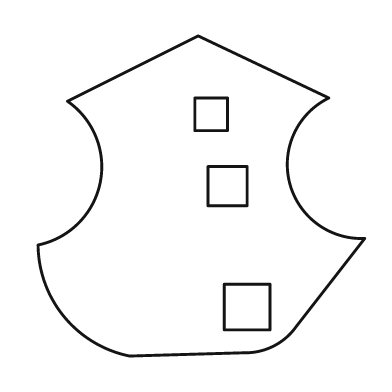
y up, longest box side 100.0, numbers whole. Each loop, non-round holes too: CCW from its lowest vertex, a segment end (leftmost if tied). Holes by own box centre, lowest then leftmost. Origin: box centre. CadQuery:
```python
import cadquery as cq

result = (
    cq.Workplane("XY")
    .moveTo(-22.0, -49.0)
    .lineTo(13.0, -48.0)
    .threePointArc((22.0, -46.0), (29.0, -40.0))
    .lineTo(50.0, -13.0)
    .threePointArc((27.0, 4.0), (39.0, 30.0))
    .lineTo(-1.0, 49.0)
    .lineTo(-41.0, 29.0)
    .threePointArc((-31.0, 4.0), (-50.0, -15.0))
    .threePointArc((-42.0, -37.0), (-22.0, -49.0))
    .close()
    .moveTo(7.0, -41.0)
    .lineTo(21.0, -41.0)
    .lineTo(21.0, -27.0)
    .lineTo(7.0, -27.0)
    .close()
    .moveTo(2.0, -3.0)
    .lineTo(14.0, -3.0)
    .lineTo(14.0, 9.0)
    .lineTo(2.0, 9.0)
    .close()
    .moveTo(-2.0, 20.0)
    .lineTo(8.0, 20.0)
    .lineTo(8.0, 30.0)
    .lineTo(-2.0, 30.0)
    .close()
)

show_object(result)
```